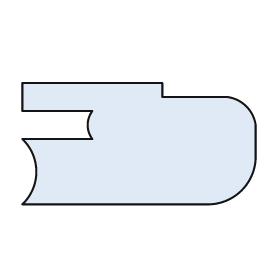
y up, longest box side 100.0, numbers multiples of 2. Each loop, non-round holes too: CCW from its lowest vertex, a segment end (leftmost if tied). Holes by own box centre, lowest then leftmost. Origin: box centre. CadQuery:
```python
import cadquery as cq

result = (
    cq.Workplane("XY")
    .moveTo(-50.0, -26.0)
    .lineTo(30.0, -26.0)
    .threePointArc((44.0, -20.0), (50.0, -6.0))
    .lineTo(50.0, 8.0)
    .threePointArc((46.0, 16.0), (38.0, 20.0))
    .lineTo(10.0, 20.0)
    .lineTo(10.0, 26.0)
    .lineTo(-50.0, 26.0)
    .lineTo(-50.0, 14.0)
    .lineTo(-20.0, 14.0)
    .threePointArc((-22.0, 8.0), (-20.0, 2.0))
    .lineTo(-50.0, 2.0)
    .threePointArc((-44.0, -12.0), (-50.0, -26.0))
    .close()
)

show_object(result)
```